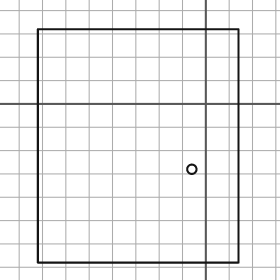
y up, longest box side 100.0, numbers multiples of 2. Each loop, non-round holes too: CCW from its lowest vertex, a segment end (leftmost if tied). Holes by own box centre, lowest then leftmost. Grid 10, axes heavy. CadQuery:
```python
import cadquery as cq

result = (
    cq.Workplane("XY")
    .moveTo(-72.0, -68.0)
    .lineTo(14.0, -68.0)
    .lineTo(14.0, 32.0)
    .lineTo(-72.0, 32.0)
    .close()
    .moveTo(-6.0, -28.0)
    .circle(2.0)
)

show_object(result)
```